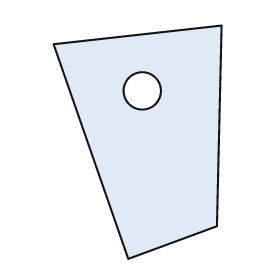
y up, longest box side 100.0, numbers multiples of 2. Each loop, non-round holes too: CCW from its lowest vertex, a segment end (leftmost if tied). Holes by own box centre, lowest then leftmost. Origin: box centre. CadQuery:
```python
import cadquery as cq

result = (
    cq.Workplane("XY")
    .moveTo(-4.0, -50.0)
    .lineTo(34.0, -36.0)
    .lineTo(36.0, 50.0)
    .lineTo(-36.0, 42.0)
    .close()
    .moveTo(2.0, 22.0)
    .circle(8.0)
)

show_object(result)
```